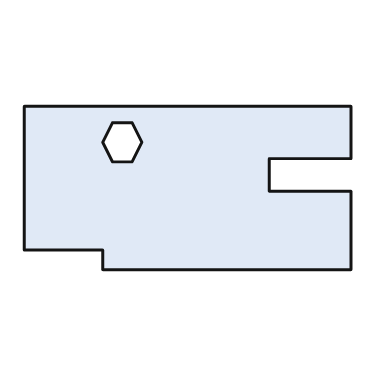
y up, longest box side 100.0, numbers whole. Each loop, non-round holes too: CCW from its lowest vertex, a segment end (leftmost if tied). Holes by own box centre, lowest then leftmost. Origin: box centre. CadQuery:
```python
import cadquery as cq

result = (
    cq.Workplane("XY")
    .moveTo(-26.0, -25.0)
    .lineTo(50.0, -25.0)
    .lineTo(50.0, -1.0)
    .lineTo(25.0, -1.0)
    .lineTo(25.0, 9.0)
    .lineTo(50.0, 9.0)
    .lineTo(50.0, 25.0)
    .lineTo(-50.0, 25.0)
    .lineTo(-50.0, -19.0)
    .lineTo(-26.0, -19.0)
    .close()
    .moveTo(-23.0, 8.0)
    .lineTo(-17.0, 8.0)
    .lineTo(-14.0, 14.0)
    .lineTo(-17.0, 20.0)
    .lineTo(-23.0, 20.0)
    .lineTo(-26.0, 14.0)
    .close()
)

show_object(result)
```